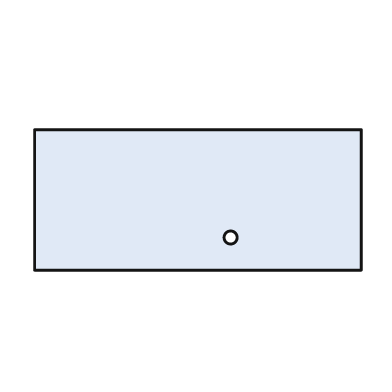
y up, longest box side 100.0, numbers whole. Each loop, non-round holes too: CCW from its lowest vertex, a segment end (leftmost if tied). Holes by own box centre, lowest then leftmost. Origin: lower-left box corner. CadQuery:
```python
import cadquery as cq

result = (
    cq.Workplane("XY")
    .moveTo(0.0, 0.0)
    .lineTo(100.0, 0.0)
    .lineTo(100.0, 43.0)
    .lineTo(0.0, 43.0)
    .close()
    .moveTo(60.0, 10.0)
    .circle(2.0)
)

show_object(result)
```